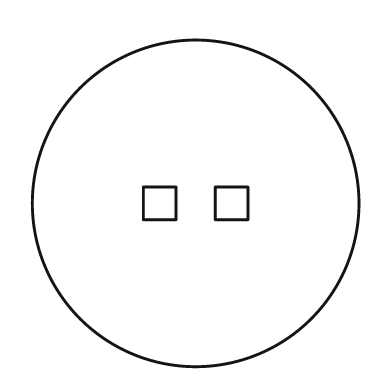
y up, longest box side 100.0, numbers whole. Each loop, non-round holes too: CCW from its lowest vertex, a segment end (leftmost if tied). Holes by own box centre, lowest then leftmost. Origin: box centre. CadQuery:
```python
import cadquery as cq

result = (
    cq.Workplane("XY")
    .moveTo(0.0, 0.0)
    .circle(50.0)
    .moveTo(-16.0, -5.0)
    .lineTo(-6.0, -5.0)
    .lineTo(-6.0, 5.0)
    .lineTo(-16.0, 5.0)
    .close()
    .moveTo(6.0, -5.0)
    .lineTo(16.0, -5.0)
    .lineTo(16.0, 5.0)
    .lineTo(6.0, 5.0)
    .close()
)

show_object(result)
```